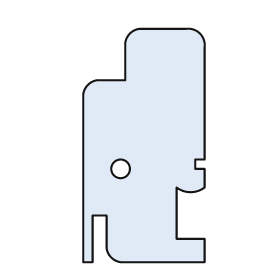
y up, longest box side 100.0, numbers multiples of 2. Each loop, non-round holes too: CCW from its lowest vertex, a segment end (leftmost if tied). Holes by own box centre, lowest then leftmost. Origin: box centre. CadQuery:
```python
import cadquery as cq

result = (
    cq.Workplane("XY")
    .moveTo(-26.0, -50.0)
    .lineTo(-22.0, -50.0)
    .lineTo(-22.0, -30.0)
    .lineTo(-16.0, -30.0)
    .lineTo(-16.0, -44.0)
    .threePointArc((-14.0, -48.0), (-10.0, -50.0))
    .lineTo(26.0, -50.0)
    .lineTo(26.0, -40.0)
    .lineTo(14.0, -40.0)
    .lineTo(14.0, -18.0)
    .threePointArc((20.0, -20.0), (26.0, -18.0))
    .lineTo(26.0, -10.0)
    .lineTo(22.0, -10.0)
    .lineTo(22.0, -6.0)
    .lineTo(26.0, -6.0)
    .lineTo(26.0, 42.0)
    .threePointArc((24.0, 48.0), (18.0, 50.0))
    .lineTo(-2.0, 50.0)
    .threePointArc((-6.0, 48.0), (-8.0, 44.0))
    .lineTo(-8.0, 28.0)
    .lineTo(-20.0, 28.0)
    .threePointArc((-24.0, 26.0), (-26.0, 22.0))
    .close()
    .moveTo(-10.0, -10.0)
    .circle(4.0)
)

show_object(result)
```